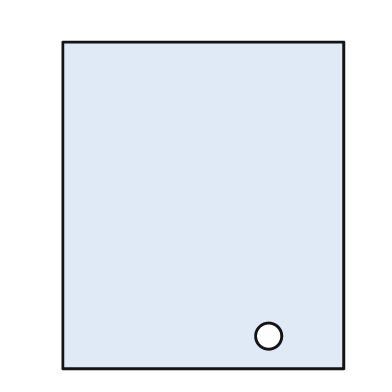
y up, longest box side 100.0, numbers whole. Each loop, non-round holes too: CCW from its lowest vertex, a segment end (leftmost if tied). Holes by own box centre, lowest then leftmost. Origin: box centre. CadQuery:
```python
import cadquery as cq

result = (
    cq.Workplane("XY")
    .moveTo(-43.0, -50.0)
    .lineTo(43.0, -50.0)
    .lineTo(43.0, 50.0)
    .lineTo(-43.0, 50.0)
    .close()
    .moveTo(20.0, -40.0)
    .circle(4.0)
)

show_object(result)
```